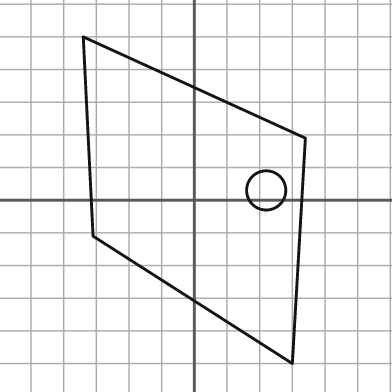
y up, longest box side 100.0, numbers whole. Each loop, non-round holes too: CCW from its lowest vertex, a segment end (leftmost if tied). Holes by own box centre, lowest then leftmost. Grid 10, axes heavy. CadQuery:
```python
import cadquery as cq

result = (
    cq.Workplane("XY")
    .moveTo(30.0, -50.0)
    .lineTo(34.0, 19.0)
    .lineTo(-34.0, 50.0)
    .lineTo(-31.0, -11.0)
    .close()
    .moveTo(22.0, 3.0)
    .circle(6.0)
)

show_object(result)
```